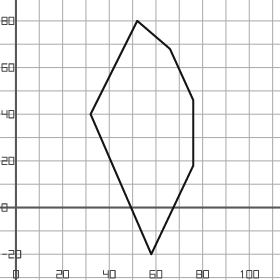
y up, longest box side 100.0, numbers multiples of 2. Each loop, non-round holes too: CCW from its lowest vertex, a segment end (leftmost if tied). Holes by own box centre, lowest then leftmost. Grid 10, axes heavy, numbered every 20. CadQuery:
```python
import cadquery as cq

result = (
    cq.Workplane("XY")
    .moveTo(58.0, -20.0)
    .lineTo(76.0, 18.0)
    .lineTo(76.0, 46.0)
    .lineTo(66.0, 68.0)
    .lineTo(52.0, 80.0)
    .lineTo(32.0, 40.0)
    .close()
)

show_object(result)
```